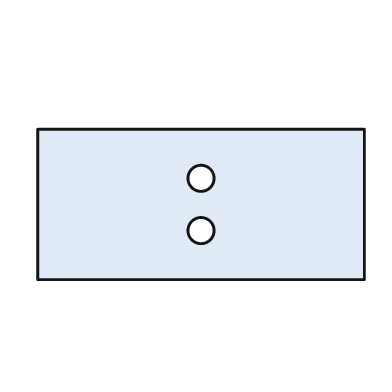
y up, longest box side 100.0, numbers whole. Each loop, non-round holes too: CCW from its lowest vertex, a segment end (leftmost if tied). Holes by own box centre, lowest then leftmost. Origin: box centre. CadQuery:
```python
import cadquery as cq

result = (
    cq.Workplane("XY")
    .moveTo(-50.0, -23.0)
    .lineTo(50.0, -23.0)
    .lineTo(50.0, 23.0)
    .lineTo(-50.0, 23.0)
    .close()
    .moveTo(0.0, -8.0)
    .circle(4.0)
    .moveTo(0.0, 8.0)
    .circle(4.0)
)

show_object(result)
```